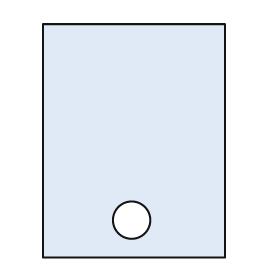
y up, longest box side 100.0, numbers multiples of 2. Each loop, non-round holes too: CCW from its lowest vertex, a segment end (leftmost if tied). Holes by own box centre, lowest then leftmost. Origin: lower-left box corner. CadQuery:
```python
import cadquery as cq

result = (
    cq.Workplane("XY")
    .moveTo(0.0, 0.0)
    .lineTo(78.0, 0.0)
    .lineTo(78.0, 100.0)
    .lineTo(0.0, 100.0)
    .close()
    .moveTo(38.0, 16.0)
    .circle(8.0)
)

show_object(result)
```